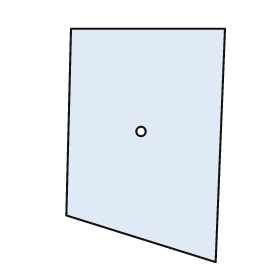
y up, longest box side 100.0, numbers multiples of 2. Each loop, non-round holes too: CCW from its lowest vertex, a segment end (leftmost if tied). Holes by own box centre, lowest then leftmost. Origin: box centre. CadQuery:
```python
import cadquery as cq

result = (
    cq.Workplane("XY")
    .moveTo(30.0, -50.0)
    .lineTo(34.0, 50.0)
    .lineTo(-32.0, 50.0)
    .lineTo(-34.0, -30.0)
    .close()
    .moveTo(-2.0, 6.0)
    .circle(2.0)
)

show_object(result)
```